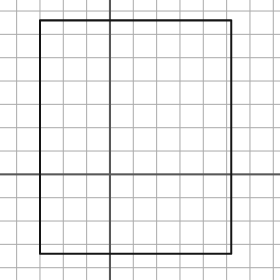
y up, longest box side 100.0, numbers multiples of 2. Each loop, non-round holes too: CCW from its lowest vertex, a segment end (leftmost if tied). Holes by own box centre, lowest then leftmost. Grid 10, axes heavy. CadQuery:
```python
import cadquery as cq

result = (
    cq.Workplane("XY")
    .moveTo(-30.0, -34.0)
    .lineTo(52.0, -34.0)
    .lineTo(52.0, 66.0)
    .lineTo(-30.0, 66.0)
    .close()
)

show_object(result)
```